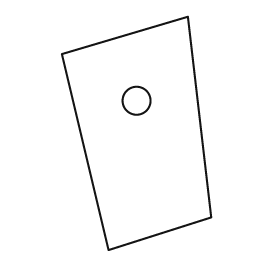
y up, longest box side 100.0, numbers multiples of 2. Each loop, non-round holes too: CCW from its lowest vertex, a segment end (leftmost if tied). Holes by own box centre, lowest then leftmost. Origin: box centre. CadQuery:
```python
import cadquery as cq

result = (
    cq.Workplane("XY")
    .moveTo(-12.0, -50.0)
    .lineTo(32.0, -36.0)
    .lineTo(22.0, 50.0)
    .lineTo(-32.0, 34.0)
    .close()
    .moveTo(0.0, 14.0)
    .circle(6.0)
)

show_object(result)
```